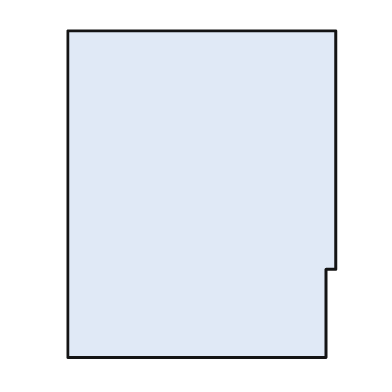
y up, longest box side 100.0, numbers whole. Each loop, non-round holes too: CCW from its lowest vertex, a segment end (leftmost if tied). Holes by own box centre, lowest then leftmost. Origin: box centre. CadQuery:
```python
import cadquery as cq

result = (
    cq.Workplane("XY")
    .moveTo(-41.0, -50.0)
    .lineTo(38.0, -50.0)
    .lineTo(38.0, -23.0)
    .lineTo(41.0, -23.0)
    .lineTo(41.0, 50.0)
    .lineTo(-41.0, 50.0)
    .close()
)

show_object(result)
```